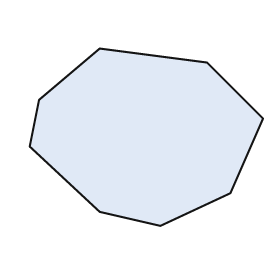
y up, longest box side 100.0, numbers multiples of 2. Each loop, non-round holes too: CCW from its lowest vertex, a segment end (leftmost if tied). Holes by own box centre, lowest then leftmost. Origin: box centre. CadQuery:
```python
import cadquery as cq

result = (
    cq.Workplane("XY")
    .moveTo(6.0, -38.0)
    .lineTo(36.0, -24.0)
    .lineTo(50.0, 8.0)
    .lineTo(26.0, 32.0)
    .lineTo(-20.0, 38.0)
    .lineTo(-46.0, 16.0)
    .lineTo(-50.0, -4.0)
    .lineTo(-20.0, -32.0)
    .close()
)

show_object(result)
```